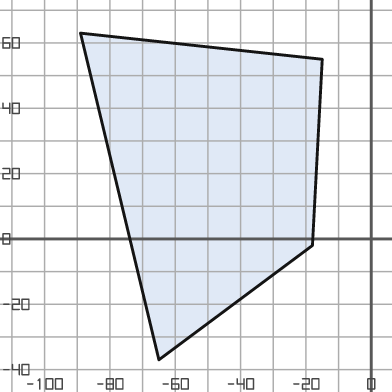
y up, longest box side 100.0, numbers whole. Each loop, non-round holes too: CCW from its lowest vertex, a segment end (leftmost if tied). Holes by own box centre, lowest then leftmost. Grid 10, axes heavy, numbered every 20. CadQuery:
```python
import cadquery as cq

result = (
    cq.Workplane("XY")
    .moveTo(-65.0, -37.0)
    .lineTo(-18.0, -2.0)
    .lineTo(-15.0, 55.0)
    .lineTo(-89.0, 63.0)
    .close()
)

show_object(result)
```